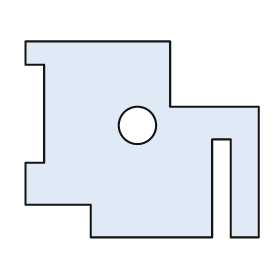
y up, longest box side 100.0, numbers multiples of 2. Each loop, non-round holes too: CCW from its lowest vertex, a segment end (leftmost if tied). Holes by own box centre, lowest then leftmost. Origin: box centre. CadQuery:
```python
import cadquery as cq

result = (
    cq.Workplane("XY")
    .moveTo(-22.0, -42.0)
    .lineTo(30.0, -42.0)
    .lineTo(30.0, 0.0)
    .lineTo(38.0, 0.0)
    .lineTo(38.0, -42.0)
    .lineTo(50.0, -42.0)
    .lineTo(50.0, 14.0)
    .lineTo(12.0, 14.0)
    .lineTo(12.0, 42.0)
    .lineTo(-50.0, 42.0)
    .lineTo(-50.0, 32.0)
    .lineTo(-42.0, 32.0)
    .lineTo(-42.0, -10.0)
    .lineTo(-50.0, -10.0)
    .lineTo(-50.0, -28.0)
    .lineTo(-22.0, -28.0)
    .close()
    .moveTo(-2.0, 6.0)
    .circle(8.0)
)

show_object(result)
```